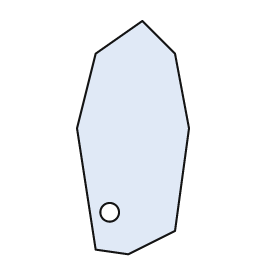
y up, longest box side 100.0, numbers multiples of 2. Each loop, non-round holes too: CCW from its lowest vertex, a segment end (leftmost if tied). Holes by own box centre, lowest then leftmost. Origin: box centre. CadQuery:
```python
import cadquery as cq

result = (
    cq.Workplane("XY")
    .moveTo(-2.0, -50.0)
    .lineTo(18.0, -40.0)
    .lineTo(24.0, 4.0)
    .lineTo(18.0, 36.0)
    .lineTo(4.0, 50.0)
    .lineTo(-16.0, 36.0)
    .lineTo(-24.0, 4.0)
    .lineTo(-16.0, -48.0)
    .close()
    .moveTo(-10.0, -32.0)
    .circle(4.0)
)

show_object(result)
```